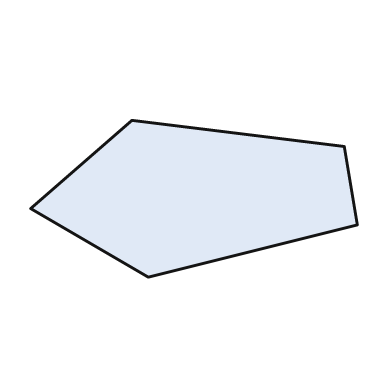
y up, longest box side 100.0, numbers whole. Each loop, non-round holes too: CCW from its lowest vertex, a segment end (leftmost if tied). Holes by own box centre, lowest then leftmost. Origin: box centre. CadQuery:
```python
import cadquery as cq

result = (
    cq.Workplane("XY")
    .moveTo(-14.0, -24.0)
    .lineTo(50.0, -8.0)
    .lineTo(46.0, 16.0)
    .lineTo(-19.0, 24.0)
    .lineTo(-50.0, -3.0)
    .close()
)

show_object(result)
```